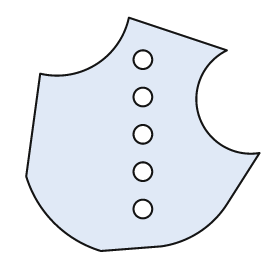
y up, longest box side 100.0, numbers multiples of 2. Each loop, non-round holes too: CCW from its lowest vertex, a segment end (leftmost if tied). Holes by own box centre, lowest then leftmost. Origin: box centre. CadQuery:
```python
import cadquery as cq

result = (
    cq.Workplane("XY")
    .moveTo(-18.0, -50.0)
    .lineTo(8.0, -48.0)
    .threePointArc((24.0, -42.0), (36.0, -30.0))
    .lineTo(50.0, -8.0)
    .threePointArc((24.0, 8.0), (36.0, 36.0))
    .lineTo(-6.0, 50.0)
    .threePointArc((-20.0, 30.0), (-44.0, 26.0))
    .lineTo(-50.0, -18.0)
    .threePointArc((-38.0, -38.0), (-18.0, -50.0))
    .close()
    .moveTo(0.0, -32.0)
    .circle(4.0)
    .moveTo(0.0, -16.0)
    .circle(4.0)
    .moveTo(0.0, 0.0)
    .circle(4.0)
    .moveTo(0.0, 16.0)
    .circle(4.0)
    .moveTo(0.0, 32.0)
    .circle(4.0)
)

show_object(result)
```